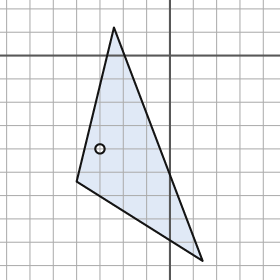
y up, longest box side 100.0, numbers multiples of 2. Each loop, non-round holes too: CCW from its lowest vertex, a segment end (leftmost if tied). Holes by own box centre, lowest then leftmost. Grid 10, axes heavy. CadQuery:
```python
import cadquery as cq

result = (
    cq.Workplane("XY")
    .moveTo(14.0, -88.0)
    .lineTo(-24.0, 12.0)
    .lineTo(-40.0, -54.0)
    .close()
    .moveTo(-30.0, -40.0)
    .circle(2.0)
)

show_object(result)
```